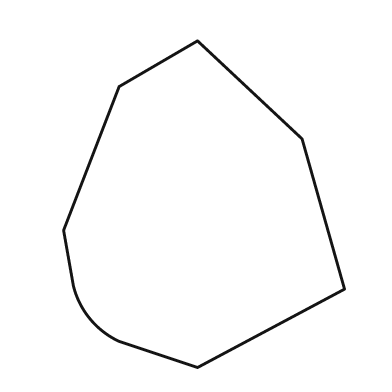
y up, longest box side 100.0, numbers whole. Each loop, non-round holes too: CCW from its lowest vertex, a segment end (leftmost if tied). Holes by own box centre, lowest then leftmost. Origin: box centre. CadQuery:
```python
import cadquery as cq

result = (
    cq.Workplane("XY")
    .moveTo(-2.0, -50.0)
    .lineTo(43.0, -26.0)
    .lineTo(30.0, 20.0)
    .lineTo(-2.0, 50.0)
    .lineTo(-26.0, 36.0)
    .lineTo(-43.0, -8.0)
    .lineTo(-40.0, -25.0)
    .threePointArc((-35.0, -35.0), (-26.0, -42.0))
    .close()
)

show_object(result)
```